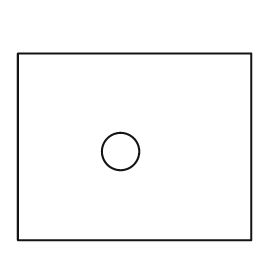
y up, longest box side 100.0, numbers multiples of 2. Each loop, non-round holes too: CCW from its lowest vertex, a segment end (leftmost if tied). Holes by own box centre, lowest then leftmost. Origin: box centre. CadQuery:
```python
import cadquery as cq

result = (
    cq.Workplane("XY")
    .moveTo(-50.0, -40.0)
    .lineTo(50.0, -40.0)
    .lineTo(50.0, 40.0)
    .lineTo(-50.0, 40.0)
    .close()
    .moveTo(-6.0, -2.0)
    .circle(8.0)
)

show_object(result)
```